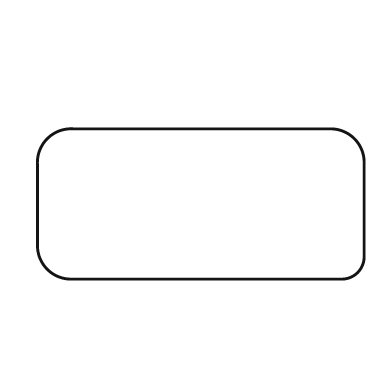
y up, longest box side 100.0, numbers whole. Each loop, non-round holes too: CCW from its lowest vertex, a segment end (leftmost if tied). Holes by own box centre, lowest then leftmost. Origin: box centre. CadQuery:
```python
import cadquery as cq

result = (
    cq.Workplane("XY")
    .moveTo(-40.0, -23.0)
    .lineTo(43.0, -23.0)
    .threePointArc((48.0, -21.0), (50.0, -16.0))
    .lineTo(50.0, 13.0)
    .threePointArc((47.0, 20.0), (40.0, 23.0))
    .lineTo(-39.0, 23.0)
    .threePointArc((-47.0, 20.0), (-50.0, 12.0))
    .lineTo(-50.0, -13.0)
    .threePointArc((-47.0, -20.0), (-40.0, -23.0))
    .close()
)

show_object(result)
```